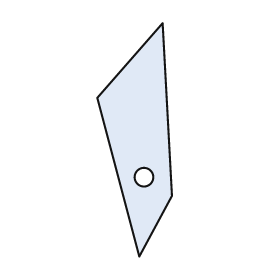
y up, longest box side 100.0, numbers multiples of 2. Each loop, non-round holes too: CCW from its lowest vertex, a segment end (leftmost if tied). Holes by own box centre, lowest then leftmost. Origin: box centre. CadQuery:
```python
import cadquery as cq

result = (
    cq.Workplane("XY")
    .moveTo(2.0, -50.0)
    .lineTo(16.0, -24.0)
    .lineTo(12.0, 50.0)
    .lineTo(-16.0, 18.0)
    .close()
    .moveTo(4.0, -16.0)
    .circle(4.0)
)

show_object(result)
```